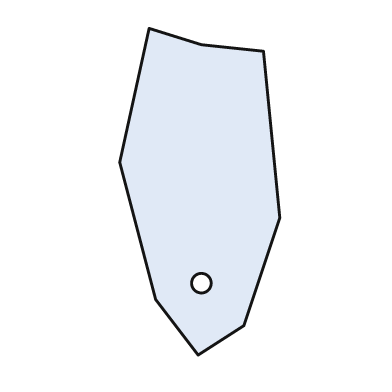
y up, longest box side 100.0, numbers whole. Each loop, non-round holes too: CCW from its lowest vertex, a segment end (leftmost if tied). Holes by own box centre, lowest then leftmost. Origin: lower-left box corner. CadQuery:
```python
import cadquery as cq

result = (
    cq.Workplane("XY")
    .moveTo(24.0, 0.0)
    .lineTo(38.0, 9.0)
    .lineTo(49.0, 42.0)
    .lineTo(44.0, 93.0)
    .lineTo(25.0, 95.0)
    .lineTo(9.0, 100.0)
    .lineTo(0.0, 59.0)
    .lineTo(11.0, 17.0)
    .close()
    .moveTo(25.0, 22.0)
    .circle(3.0)
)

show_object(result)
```